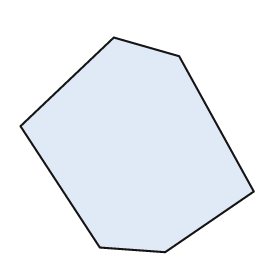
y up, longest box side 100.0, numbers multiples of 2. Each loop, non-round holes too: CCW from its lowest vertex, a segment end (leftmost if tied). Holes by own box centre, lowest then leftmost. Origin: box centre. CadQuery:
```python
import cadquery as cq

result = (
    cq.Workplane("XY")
    .moveTo(12.0, -46.0)
    .lineTo(50.0, -20.0)
    .lineTo(18.0, 38.0)
    .lineTo(-10.0, 46.0)
    .lineTo(-50.0, 8.0)
    .lineTo(-16.0, -44.0)
    .close()
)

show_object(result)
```